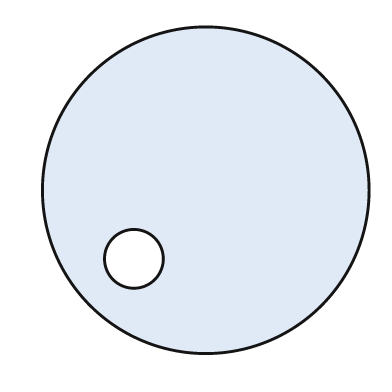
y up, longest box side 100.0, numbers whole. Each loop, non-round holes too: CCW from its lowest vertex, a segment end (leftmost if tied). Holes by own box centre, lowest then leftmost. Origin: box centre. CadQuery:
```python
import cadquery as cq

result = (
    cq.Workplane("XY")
    .moveTo(0.0, 0.0)
    .circle(50.0)
    .moveTo(-22.0, -21.0)
    .circle(9.0)
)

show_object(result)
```